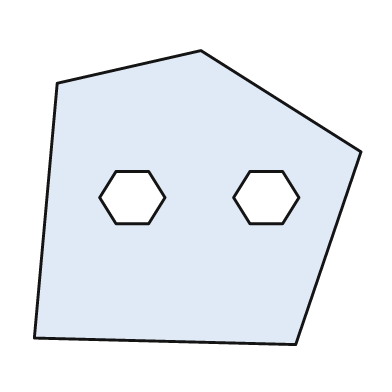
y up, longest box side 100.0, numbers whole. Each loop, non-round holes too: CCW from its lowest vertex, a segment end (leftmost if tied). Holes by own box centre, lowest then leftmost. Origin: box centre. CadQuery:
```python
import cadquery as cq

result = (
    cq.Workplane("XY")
    .moveTo(30.0, -45.0)
    .lineTo(50.0, 14.0)
    .lineTo(1.0, 45.0)
    .lineTo(-43.0, 35.0)
    .lineTo(-50.0, -43.0)
    .close()
    .moveTo(-25.0, -8.0)
    .lineTo(-15.0, -8.0)
    .lineTo(-10.0, 0.0)
    .lineTo(-15.0, 8.0)
    .lineTo(-25.0, 8.0)
    .lineTo(-30.0, 0.0)
    .close()
    .moveTo(16.0, -8.0)
    .lineTo(26.0, -8.0)
    .lineTo(31.0, 0.0)
    .lineTo(26.0, 8.0)
    .lineTo(16.0, 8.0)
    .lineTo(11.0, 0.0)
    .close()
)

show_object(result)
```